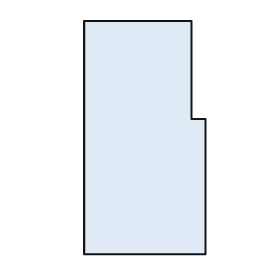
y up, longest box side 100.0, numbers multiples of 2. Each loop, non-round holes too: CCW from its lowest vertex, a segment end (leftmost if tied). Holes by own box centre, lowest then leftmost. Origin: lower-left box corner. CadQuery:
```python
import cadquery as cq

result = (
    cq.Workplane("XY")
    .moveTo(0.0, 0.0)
    .lineTo(52.0, 0.0)
    .lineTo(52.0, 58.0)
    .lineTo(46.0, 58.0)
    .lineTo(46.0, 100.0)
    .lineTo(0.0, 100.0)
    .close()
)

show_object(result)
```